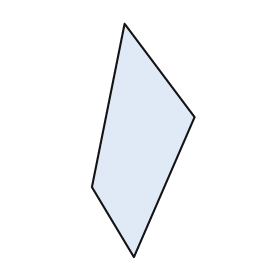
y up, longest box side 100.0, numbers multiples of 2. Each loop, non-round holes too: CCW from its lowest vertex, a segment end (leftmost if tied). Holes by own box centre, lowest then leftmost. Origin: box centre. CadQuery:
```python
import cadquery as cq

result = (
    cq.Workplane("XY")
    .moveTo(-4.0, -50.0)
    .lineTo(22.0, 10.0)
    .lineTo(-8.0, 50.0)
    .lineTo(-22.0, -20.0)
    .close()
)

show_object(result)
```